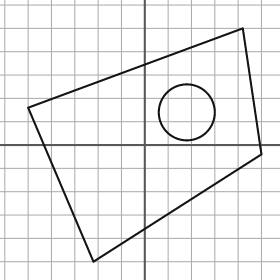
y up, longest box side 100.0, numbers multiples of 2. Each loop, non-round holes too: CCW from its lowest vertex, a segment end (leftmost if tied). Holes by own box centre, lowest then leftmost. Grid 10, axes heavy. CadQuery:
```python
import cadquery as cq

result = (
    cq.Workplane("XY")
    .moveTo(-22.0, -50.0)
    .lineTo(50.0, -4.0)
    .lineTo(42.0, 50.0)
    .lineTo(-50.0, 16.0)
    .close()
    .moveTo(18.0, 14.0)
    .circle(12.0)
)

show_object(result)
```